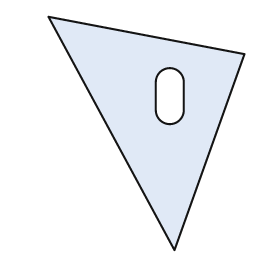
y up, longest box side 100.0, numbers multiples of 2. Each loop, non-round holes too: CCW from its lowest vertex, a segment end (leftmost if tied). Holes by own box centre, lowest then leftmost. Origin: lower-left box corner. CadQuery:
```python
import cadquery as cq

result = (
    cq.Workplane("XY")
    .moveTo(54.0, 0.0)
    .lineTo(84.0, 84.0)
    .lineTo(0.0, 100.0)
    .close()
    .moveTo(46.0, 60.0)
    .threePointArc((52.0, 54.0), (58.0, 60.0))
    .lineTo(58.0, 72.0)
    .threePointArc((52.0, 78.0), (46.0, 72.0))
    .close()
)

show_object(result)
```